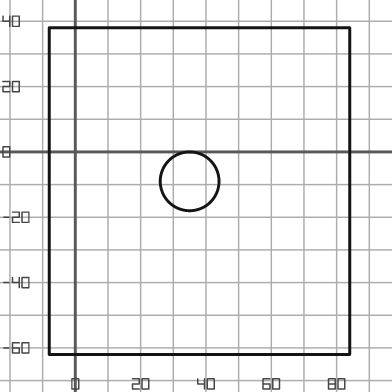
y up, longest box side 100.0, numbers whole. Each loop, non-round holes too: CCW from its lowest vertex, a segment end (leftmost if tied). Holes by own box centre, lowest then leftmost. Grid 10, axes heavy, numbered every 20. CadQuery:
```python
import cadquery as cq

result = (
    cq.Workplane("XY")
    .moveTo(-8.0, -62.0)
    .lineTo(84.0, -62.0)
    .lineTo(84.0, 38.0)
    .lineTo(-8.0, 38.0)
    .close()
    .moveTo(35.0, -9.0)
    .circle(9.0)
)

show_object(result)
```